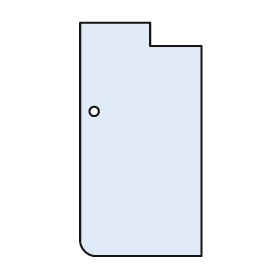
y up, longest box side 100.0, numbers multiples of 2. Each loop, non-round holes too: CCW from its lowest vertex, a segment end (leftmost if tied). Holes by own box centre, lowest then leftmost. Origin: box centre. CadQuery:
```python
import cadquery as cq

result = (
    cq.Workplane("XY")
    .moveTo(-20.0, -50.0)
    .lineTo(26.0, -50.0)
    .lineTo(26.0, 40.0)
    .lineTo(4.0, 40.0)
    .lineTo(4.0, 50.0)
    .lineTo(-26.0, 50.0)
    .lineTo(-26.0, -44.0)
    .threePointArc((-24.0, -48.0), (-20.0, -50.0))
    .close()
    .moveTo(-20.0, 12.0)
    .circle(2.0)
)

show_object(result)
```